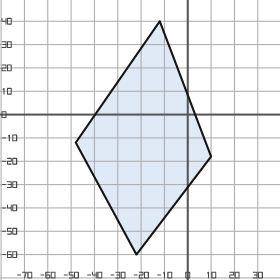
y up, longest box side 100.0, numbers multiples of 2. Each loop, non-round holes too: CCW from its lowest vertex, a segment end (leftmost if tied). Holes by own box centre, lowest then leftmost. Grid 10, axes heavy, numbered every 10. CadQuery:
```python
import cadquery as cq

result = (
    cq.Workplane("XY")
    .moveTo(-22.0, -60.0)
    .lineTo(10.0, -18.0)
    .lineTo(-12.0, 40.0)
    .lineTo(-48.0, -12.0)
    .close()
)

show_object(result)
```